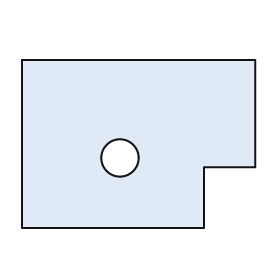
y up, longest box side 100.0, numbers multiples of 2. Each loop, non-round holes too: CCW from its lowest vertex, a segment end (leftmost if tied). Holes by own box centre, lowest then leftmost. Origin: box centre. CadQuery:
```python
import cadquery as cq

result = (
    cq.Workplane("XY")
    .moveTo(-50.0, -36.0)
    .lineTo(28.0, -36.0)
    .lineTo(28.0, -10.0)
    .lineTo(50.0, -10.0)
    .lineTo(50.0, 36.0)
    .lineTo(-50.0, 36.0)
    .close()
    .moveTo(-8.0, -6.0)
    .circle(8.0)
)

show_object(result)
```